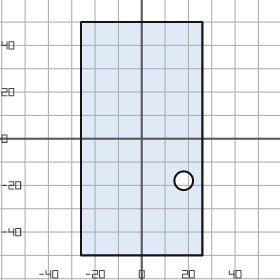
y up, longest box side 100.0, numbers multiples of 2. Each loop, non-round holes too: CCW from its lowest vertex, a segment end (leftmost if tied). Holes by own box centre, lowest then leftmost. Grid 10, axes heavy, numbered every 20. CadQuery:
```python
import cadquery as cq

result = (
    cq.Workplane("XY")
    .moveTo(-26.0, -50.0)
    .lineTo(26.0, -50.0)
    .lineTo(26.0, 50.0)
    .lineTo(-26.0, 50.0)
    .close()
    .moveTo(18.0, -18.0)
    .circle(4.0)
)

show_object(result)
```